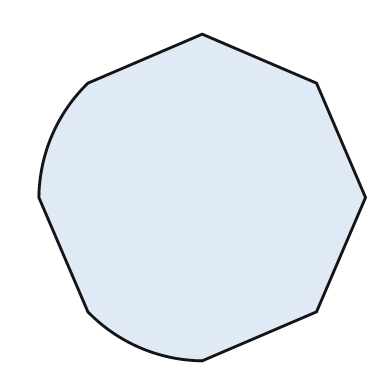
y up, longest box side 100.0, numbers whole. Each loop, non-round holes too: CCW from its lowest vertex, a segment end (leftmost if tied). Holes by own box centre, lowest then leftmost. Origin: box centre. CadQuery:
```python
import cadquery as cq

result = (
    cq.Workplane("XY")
    .moveTo(0.0, -50.0)
    .lineTo(35.0, -35.0)
    .lineTo(50.0, 0.0)
    .lineTo(35.0, 35.0)
    .lineTo(0.0, 50.0)
    .lineTo(-35.0, 35.0)
    .threePointArc((-46.0, 19.0), (-50.0, 0.0))
    .lineTo(-35.0, -35.0)
    .threePointArc((-19.0, -46.0), (0.0, -50.0))
    .close()
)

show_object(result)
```